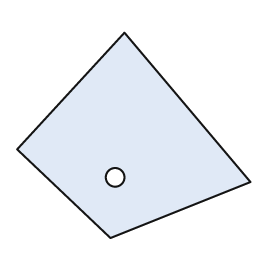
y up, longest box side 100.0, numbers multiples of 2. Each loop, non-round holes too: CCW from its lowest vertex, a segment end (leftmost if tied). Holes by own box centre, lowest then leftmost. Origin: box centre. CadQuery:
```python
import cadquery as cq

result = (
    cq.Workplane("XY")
    .moveTo(-10.0, -44.0)
    .lineTo(50.0, -20.0)
    .lineTo(-4.0, 44.0)
    .lineTo(-50.0, -6.0)
    .close()
    .moveTo(-8.0, -18.0)
    .circle(4.0)
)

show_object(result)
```